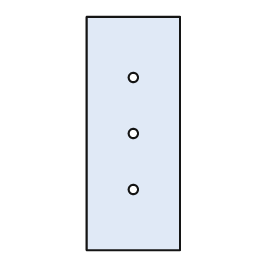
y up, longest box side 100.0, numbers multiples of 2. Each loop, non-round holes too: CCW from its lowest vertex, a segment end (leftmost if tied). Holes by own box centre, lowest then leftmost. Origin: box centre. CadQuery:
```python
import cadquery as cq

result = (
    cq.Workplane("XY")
    .moveTo(-20.0, -50.0)
    .lineTo(20.0, -50.0)
    .lineTo(20.0, 50.0)
    .lineTo(-20.0, 50.0)
    .close()
    .moveTo(0.0, -24.0)
    .circle(2.0)
    .moveTo(0.0, 0.0)
    .circle(2.0)
    .moveTo(0.0, 24.0)
    .circle(2.0)
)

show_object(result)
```